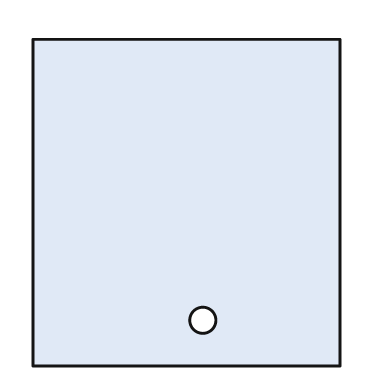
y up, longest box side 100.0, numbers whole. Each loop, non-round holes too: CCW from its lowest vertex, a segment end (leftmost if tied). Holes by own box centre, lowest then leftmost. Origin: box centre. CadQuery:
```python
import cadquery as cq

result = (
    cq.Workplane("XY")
    .moveTo(-47.0, -50.0)
    .lineTo(47.0, -50.0)
    .lineTo(47.0, 50.0)
    .lineTo(-47.0, 50.0)
    .close()
    .moveTo(5.0, -36.0)
    .circle(4.0)
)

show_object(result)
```